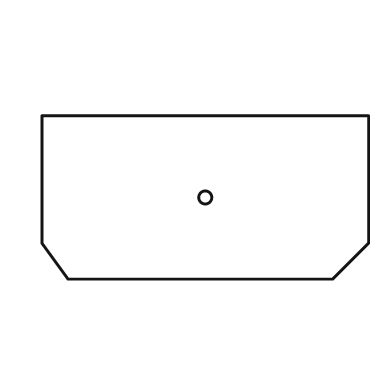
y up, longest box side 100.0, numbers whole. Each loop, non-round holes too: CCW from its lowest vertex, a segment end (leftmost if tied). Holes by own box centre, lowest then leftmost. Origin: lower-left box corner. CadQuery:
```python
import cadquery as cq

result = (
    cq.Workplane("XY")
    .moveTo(8.0, 0.0)
    .lineTo(89.0, 0.0)
    .lineTo(100.0, 11.0)
    .lineTo(100.0, 50.0)
    .lineTo(0.0, 50.0)
    .lineTo(0.0, 11.0)
    .close()
    .moveTo(50.0, 25.0)
    .circle(2.0)
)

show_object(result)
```